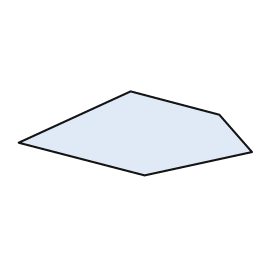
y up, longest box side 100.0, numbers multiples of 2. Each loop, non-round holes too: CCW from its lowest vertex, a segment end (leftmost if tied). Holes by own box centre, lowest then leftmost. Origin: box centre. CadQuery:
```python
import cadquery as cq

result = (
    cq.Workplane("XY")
    .moveTo(4.0, -18.0)
    .lineTo(50.0, -8.0)
    .lineTo(36.0, 8.0)
    .lineTo(-2.0, 18.0)
    .lineTo(-50.0, -4.0)
    .close()
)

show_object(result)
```